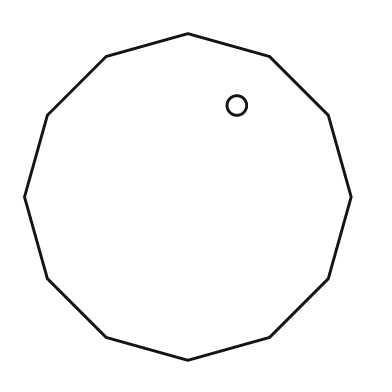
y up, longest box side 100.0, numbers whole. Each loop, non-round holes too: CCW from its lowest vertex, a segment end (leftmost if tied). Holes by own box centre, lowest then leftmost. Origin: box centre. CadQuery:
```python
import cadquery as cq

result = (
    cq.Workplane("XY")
    .moveTo(0.0, -50.0)
    .lineTo(25.0, -43.0)
    .lineTo(43.0, -25.0)
    .lineTo(50.0, 0.0)
    .lineTo(43.0, 25.0)
    .lineTo(25.0, 43.0)
    .lineTo(0.0, 50.0)
    .lineTo(-25.0, 43.0)
    .lineTo(-43.0, 25.0)
    .lineTo(-50.0, 0.0)
    .lineTo(-43.0, -25.0)
    .lineTo(-25.0, -43.0)
    .close()
    .moveTo(15.0, 28.0)
    .circle(3.0)
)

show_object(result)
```